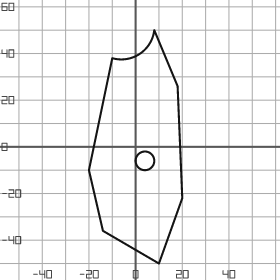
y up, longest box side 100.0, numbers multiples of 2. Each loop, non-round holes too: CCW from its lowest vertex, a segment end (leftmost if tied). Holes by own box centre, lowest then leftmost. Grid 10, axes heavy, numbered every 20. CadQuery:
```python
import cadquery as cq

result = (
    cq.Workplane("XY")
    .moveTo(10.0, -50.0)
    .lineTo(20.0, -22.0)
    .lineTo(18.0, 26.0)
    .lineTo(8.0, 50.0)
    .threePointArc((2.0, 40.0), (-10.0, 38.0))
    .lineTo(-20.0, -10.0)
    .lineTo(-14.0, -36.0)
    .close()
    .moveTo(4.0, -6.0)
    .circle(4.0)
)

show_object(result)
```